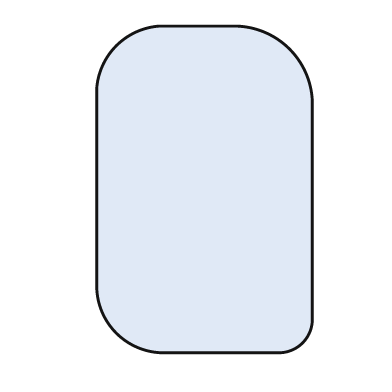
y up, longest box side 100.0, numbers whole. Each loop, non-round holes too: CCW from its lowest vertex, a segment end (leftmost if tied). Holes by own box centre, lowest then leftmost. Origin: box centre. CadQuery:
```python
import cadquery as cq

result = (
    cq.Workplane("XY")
    .moveTo(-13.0, -50.0)
    .lineTo(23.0, -50.0)
    .threePointArc((30.0, -47.0), (33.0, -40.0))
    .lineTo(33.0, 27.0)
    .threePointArc((26.0, 43.0), (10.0, 50.0))
    .lineTo(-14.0, 50.0)
    .threePointArc((-27.0, 44.0), (-33.0, 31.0))
    .lineTo(-33.0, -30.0)
    .threePointArc((-27.0, -44.0), (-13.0, -50.0))
    .close()
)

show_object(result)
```